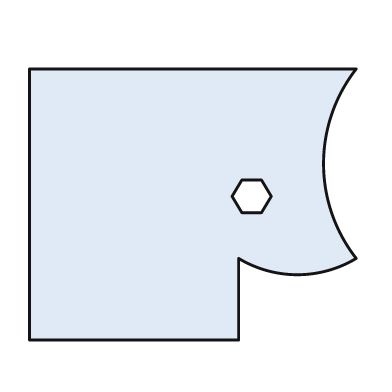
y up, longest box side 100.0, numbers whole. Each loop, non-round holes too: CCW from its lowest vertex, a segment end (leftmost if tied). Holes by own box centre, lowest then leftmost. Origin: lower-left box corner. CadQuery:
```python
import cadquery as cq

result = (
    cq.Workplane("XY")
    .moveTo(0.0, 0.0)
    .lineTo(64.0, 0.0)
    .lineTo(64.0, 25.0)
    .threePointArc((82.0, 20.0), (100.0, 25.0))
    .threePointArc((90.0, 54.0), (100.0, 83.0))
    .lineTo(0.0, 83.0)
    .close()
    .moveTo(65.0, 39.0)
    .lineTo(71.0, 39.0)
    .lineTo(74.0, 44.0)
    .lineTo(71.0, 49.0)
    .lineTo(65.0, 49.0)
    .lineTo(62.0, 44.0)
    .close()
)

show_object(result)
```